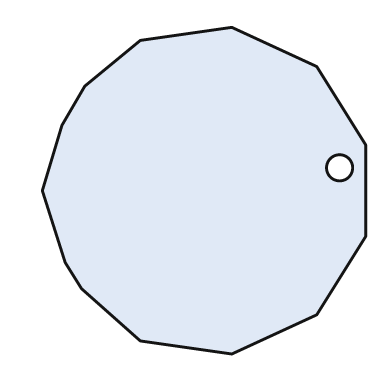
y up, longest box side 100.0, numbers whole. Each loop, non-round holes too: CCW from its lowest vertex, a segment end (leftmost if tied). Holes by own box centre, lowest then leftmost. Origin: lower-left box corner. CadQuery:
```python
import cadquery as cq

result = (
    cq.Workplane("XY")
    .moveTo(58.0, 0.0)
    .lineTo(84.0, 12.0)
    .lineTo(99.0, 36.0)
    .lineTo(99.0, 64.0)
    .lineTo(84.0, 88.0)
    .lineTo(58.0, 100.0)
    .lineTo(30.0, 96.0)
    .lineTo(13.0, 82.0)
    .lineTo(6.0, 70.0)
    .lineTo(0.0, 50.0)
    .lineTo(7.0, 28.0)
    .lineTo(12.0, 20.0)
    .lineTo(30.0, 4.0)
    .close()
    .moveTo(91.0, 57.0)
    .circle(4.0)
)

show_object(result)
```